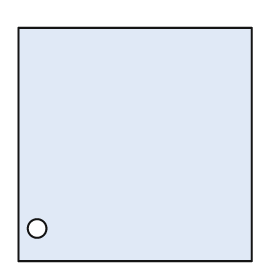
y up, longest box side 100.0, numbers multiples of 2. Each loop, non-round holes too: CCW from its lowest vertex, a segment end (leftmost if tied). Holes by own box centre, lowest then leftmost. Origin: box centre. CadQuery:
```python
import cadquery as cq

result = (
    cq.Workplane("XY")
    .moveTo(-50.0, -50.0)
    .lineTo(50.0, -50.0)
    .lineTo(50.0, 50.0)
    .lineTo(-50.0, 50.0)
    .close()
    .moveTo(-42.0, -36.0)
    .circle(4.0)
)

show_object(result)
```